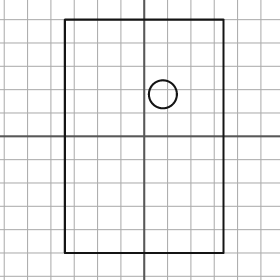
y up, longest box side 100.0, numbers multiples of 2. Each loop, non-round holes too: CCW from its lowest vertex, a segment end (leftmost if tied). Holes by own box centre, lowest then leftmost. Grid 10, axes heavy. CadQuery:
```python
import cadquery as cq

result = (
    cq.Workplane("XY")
    .moveTo(-34.0, -50.0)
    .lineTo(34.0, -50.0)
    .lineTo(34.0, 50.0)
    .lineTo(-34.0, 50.0)
    .close()
    .moveTo(8.0, 18.0)
    .circle(6.0)
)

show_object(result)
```